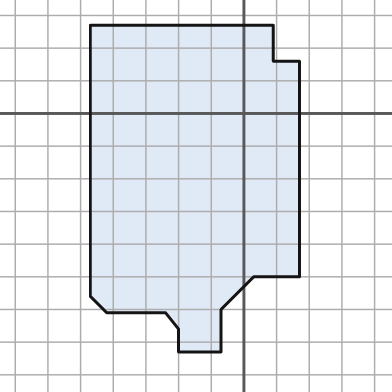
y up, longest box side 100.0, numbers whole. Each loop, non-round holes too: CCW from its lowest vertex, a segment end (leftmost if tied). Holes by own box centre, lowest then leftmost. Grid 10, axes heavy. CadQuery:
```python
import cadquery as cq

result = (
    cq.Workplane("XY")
    .moveTo(-20.0, -73.0)
    .lineTo(-7.0, -73.0)
    .lineTo(-7.0, -60.0)
    .lineTo(3.0, -50.0)
    .lineTo(17.0, -50.0)
    .lineTo(17.0, 16.0)
    .lineTo(9.0, 16.0)
    .lineTo(9.0, 27.0)
    .lineTo(-47.0, 27.0)
    .lineTo(-47.0, -56.0)
    .lineTo(-42.0, -61.0)
    .lineTo(-24.0, -61.0)
    .lineTo(-20.0, -66.0)
    .close()
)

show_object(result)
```